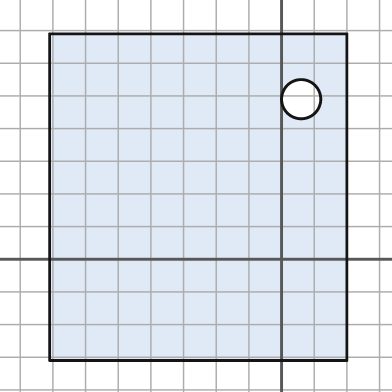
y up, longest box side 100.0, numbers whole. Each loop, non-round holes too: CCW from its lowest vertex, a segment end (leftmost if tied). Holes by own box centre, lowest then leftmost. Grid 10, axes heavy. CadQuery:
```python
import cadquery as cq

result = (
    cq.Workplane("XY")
    .moveTo(-71.0, -31.0)
    .lineTo(20.0, -31.0)
    .lineTo(20.0, 69.0)
    .lineTo(-71.0, 69.0)
    .close()
    .moveTo(6.0, 49.0)
    .circle(6.0)
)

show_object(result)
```